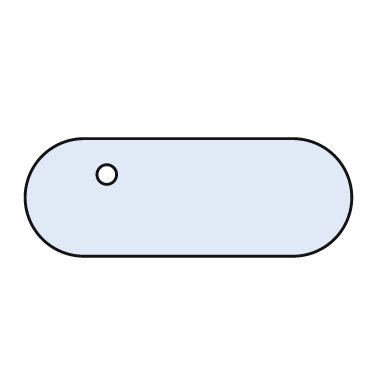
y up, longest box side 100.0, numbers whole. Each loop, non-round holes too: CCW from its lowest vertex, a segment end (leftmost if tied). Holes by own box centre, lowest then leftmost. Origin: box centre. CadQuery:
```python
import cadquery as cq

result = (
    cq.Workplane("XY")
    .moveTo(-32.0, -18.0)
    .lineTo(32.0, -18.0)
    .threePointArc((50.0, 0.0), (32.0, 18.0))
    .lineTo(-32.0, 18.0)
    .threePointArc((-50.0, 0.0), (-32.0, -18.0))
    .close()
    .moveTo(-25.0, 7.0)
    .circle(3.0)
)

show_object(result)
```